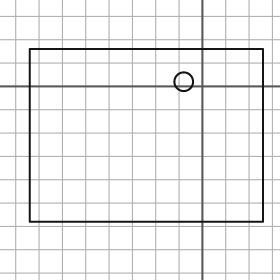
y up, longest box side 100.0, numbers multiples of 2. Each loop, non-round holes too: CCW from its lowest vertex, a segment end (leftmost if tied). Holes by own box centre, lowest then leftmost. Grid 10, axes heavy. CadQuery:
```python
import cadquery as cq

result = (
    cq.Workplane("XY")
    .moveTo(-74.0, -58.0)
    .lineTo(26.0, -58.0)
    .lineTo(26.0, 16.0)
    .lineTo(-74.0, 16.0)
    .close()
    .moveTo(-8.0, 2.0)
    .circle(4.0)
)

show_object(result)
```